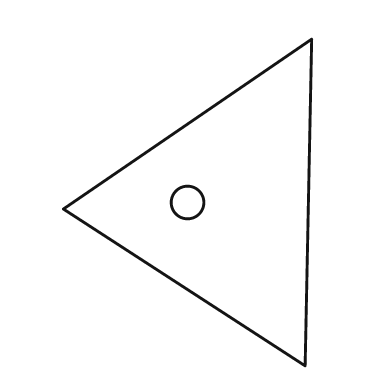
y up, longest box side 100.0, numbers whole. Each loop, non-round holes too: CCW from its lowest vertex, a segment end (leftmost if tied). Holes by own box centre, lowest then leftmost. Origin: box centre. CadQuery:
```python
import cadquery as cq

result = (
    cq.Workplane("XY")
    .moveTo(36.0, -50.0)
    .lineTo(38.0, 50.0)
    .lineTo(-38.0, -2.0)
    .close()
    .moveTo(0.0, 0.0)
    .circle(5.0)
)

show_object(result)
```